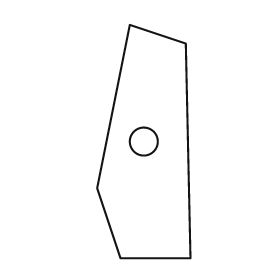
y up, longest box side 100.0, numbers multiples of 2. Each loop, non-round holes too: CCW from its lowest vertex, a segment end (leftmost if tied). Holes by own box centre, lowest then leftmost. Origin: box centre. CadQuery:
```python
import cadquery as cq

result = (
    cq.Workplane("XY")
    .moveTo(-10.0, -50.0)
    .lineTo(20.0, -50.0)
    .lineTo(18.0, 42.0)
    .lineTo(-6.0, 50.0)
    .lineTo(-20.0, -20.0)
    .close()
    .moveTo(0.0, 0.0)
    .circle(6.0)
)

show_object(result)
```